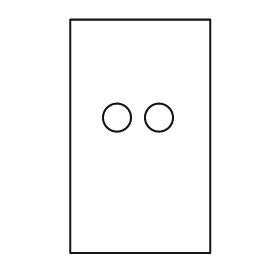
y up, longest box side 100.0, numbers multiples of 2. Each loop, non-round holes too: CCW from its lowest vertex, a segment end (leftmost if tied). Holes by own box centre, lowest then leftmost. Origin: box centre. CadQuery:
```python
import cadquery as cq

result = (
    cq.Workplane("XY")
    .moveTo(-30.0, -50.0)
    .lineTo(30.0, -50.0)
    .lineTo(30.0, 50.0)
    .lineTo(-30.0, 50.0)
    .close()
    .moveTo(-10.0, 8.0)
    .circle(6.0)
    .moveTo(8.0, 8.0)
    .circle(6.0)
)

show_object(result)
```